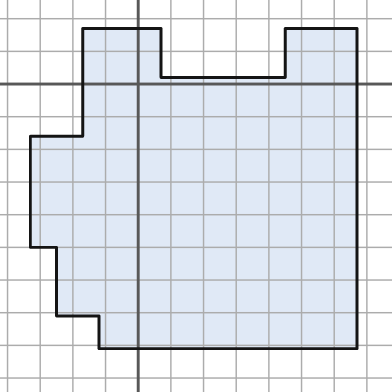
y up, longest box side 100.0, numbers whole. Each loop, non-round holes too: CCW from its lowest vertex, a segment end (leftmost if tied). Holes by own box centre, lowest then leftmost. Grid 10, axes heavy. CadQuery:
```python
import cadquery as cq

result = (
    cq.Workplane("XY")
    .moveTo(-12.0, -81.0)
    .lineTo(67.0, -81.0)
    .lineTo(67.0, 17.0)
    .lineTo(45.0, 17.0)
    .lineTo(45.0, 2.0)
    .lineTo(7.0, 2.0)
    .lineTo(7.0, 17.0)
    .lineTo(-17.0, 17.0)
    .lineTo(-17.0, -16.0)
    .lineTo(-33.0, -16.0)
    .lineTo(-33.0, -50.0)
    .lineTo(-25.0, -50.0)
    .lineTo(-25.0, -71.0)
    .lineTo(-12.0, -71.0)
    .close()
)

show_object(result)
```